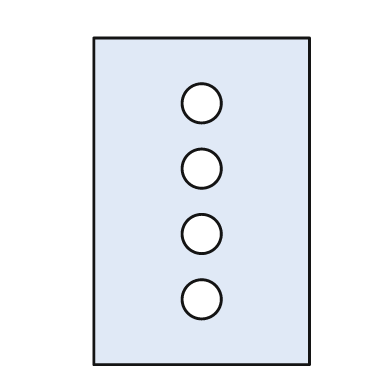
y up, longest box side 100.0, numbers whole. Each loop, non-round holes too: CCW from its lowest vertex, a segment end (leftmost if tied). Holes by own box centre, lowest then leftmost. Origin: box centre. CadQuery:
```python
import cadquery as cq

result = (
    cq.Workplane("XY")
    .moveTo(-33.0, -50.0)
    .lineTo(33.0, -50.0)
    .lineTo(33.0, 50.0)
    .lineTo(-33.0, 50.0)
    .close()
    .moveTo(0.0, -30.0)
    .circle(6.0)
    .moveTo(0.0, -10.0)
    .circle(6.0)
    .moveTo(0.0, 10.0)
    .circle(6.0)
    .moveTo(0.0, 30.0)
    .circle(6.0)
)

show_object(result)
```